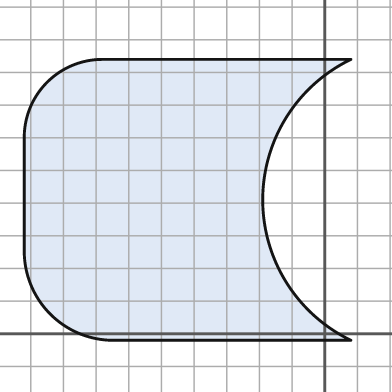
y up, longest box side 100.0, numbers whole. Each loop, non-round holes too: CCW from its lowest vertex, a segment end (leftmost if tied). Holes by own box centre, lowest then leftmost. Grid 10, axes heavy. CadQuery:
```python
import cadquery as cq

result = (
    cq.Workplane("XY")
    .moveTo(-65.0, -2.0)
    .lineTo(8.0, -2.0)
    .threePointArc((-19.0, 41.0), (8.0, 84.0))
    .lineTo(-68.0, 84.0)
    .threePointArc((-85.0, 77.0), (-92.0, 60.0))
    .lineTo(-92.0, 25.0)
    .threePointArc((-84.0, 6.0), (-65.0, -2.0))
    .close()
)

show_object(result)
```